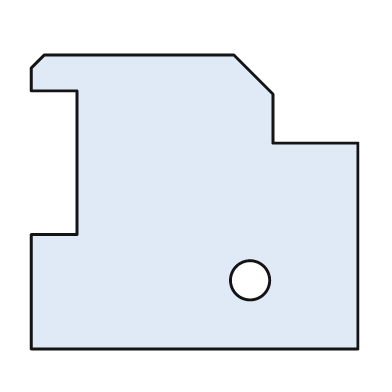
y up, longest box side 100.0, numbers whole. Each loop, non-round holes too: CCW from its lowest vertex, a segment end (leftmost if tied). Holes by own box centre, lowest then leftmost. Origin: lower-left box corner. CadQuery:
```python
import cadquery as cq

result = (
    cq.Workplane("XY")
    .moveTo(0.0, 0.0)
    .lineTo(100.0, 0.0)
    .lineTo(100.0, 63.0)
    .lineTo(74.0, 63.0)
    .lineTo(74.0, 78.0)
    .lineTo(62.0, 90.0)
    .lineTo(4.0, 90.0)
    .lineTo(0.0, 86.0)
    .lineTo(0.0, 79.0)
    .lineTo(14.0, 79.0)
    .lineTo(14.0, 35.0)
    .lineTo(0.0, 35.0)
    .close()
    .moveTo(67.0, 21.0)
    .circle(6.0)
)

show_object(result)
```